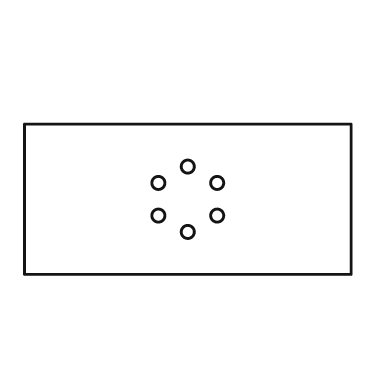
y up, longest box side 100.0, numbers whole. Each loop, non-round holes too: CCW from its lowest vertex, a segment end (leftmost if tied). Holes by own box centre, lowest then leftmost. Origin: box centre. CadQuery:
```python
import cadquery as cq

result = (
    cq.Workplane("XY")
    .moveTo(-50.0, -23.0)
    .lineTo(50.0, -23.0)
    .lineTo(50.0, 23.0)
    .lineTo(-50.0, 23.0)
    .close()
    .moveTo(0.0, -10.0)
    .circle(2.0)
    .moveTo(-9.0, -5.0)
    .circle(2.0)
    .moveTo(9.0, -5.0)
    .circle(2.0)
    .moveTo(-9.0, 5.0)
    .circle(2.0)
    .moveTo(9.0, 5.0)
    .circle(2.0)
    .moveTo(0.0, 10.0)
    .circle(2.0)
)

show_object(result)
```